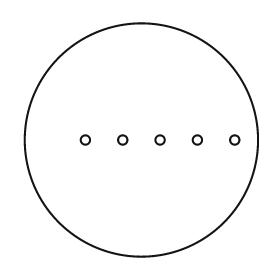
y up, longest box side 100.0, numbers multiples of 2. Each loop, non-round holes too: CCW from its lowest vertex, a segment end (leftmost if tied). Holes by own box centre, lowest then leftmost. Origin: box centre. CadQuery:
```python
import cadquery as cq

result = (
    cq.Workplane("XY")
    .moveTo(0.0, 0.0)
    .circle(50.0)
    .moveTo(-24.0, 0.0)
    .circle(2.0)
    .moveTo(-8.0, 0.0)
    .circle(2.0)
    .moveTo(8.0, 0.0)
    .circle(2.0)
    .moveTo(24.0, 0.0)
    .circle(2.0)
    .moveTo(40.0, 0.0)
    .circle(2.0)
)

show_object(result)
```